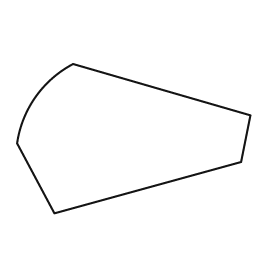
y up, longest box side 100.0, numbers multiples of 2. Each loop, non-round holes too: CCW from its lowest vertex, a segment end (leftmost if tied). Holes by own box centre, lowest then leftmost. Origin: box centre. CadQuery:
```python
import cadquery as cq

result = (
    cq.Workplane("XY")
    .moveTo(-34.0, -32.0)
    .lineTo(46.0, -10.0)
    .lineTo(50.0, 10.0)
    .lineTo(-26.0, 32.0)
    .threePointArc((-42.0, 18.0), (-50.0, -2.0))
    .close()
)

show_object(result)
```